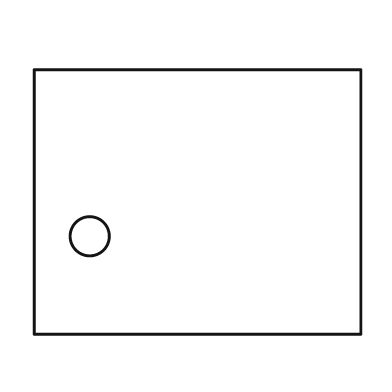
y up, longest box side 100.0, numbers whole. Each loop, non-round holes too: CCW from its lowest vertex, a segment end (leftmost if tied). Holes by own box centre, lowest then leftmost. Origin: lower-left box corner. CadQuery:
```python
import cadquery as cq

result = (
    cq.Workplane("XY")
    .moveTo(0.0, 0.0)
    .lineTo(100.0, 0.0)
    .lineTo(100.0, 81.0)
    .lineTo(0.0, 81.0)
    .close()
    .moveTo(17.0, 30.0)
    .circle(6.0)
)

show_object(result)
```